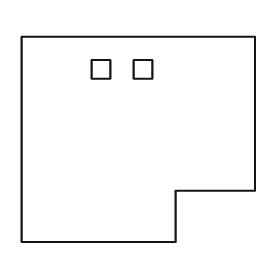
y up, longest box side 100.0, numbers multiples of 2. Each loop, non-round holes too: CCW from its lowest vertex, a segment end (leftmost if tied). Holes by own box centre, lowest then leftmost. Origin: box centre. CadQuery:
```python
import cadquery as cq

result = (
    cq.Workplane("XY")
    .moveTo(-50.0, -44.0)
    .lineTo(16.0, -44.0)
    .lineTo(16.0, -22.0)
    .lineTo(50.0, -22.0)
    .lineTo(50.0, 44.0)
    .lineTo(-50.0, 44.0)
    .close()
    .moveTo(-20.0, 26.0)
    .lineTo(-12.0, 26.0)
    .lineTo(-12.0, 34.0)
    .lineTo(-20.0, 34.0)
    .close()
    .moveTo(-2.0, 26.0)
    .lineTo(6.0, 26.0)
    .lineTo(6.0, 34.0)
    .lineTo(-2.0, 34.0)
    .close()
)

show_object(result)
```